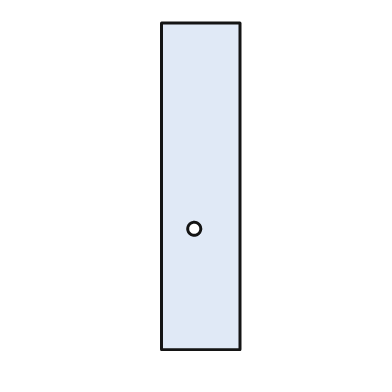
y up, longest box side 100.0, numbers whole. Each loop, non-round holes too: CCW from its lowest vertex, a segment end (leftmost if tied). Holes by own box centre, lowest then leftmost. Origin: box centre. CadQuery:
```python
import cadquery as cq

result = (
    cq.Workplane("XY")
    .moveTo(-12.0, -50.0)
    .lineTo(12.0, -50.0)
    .lineTo(12.0, 50.0)
    .lineTo(-12.0, 50.0)
    .close()
    .moveTo(-2.0, -13.0)
    .circle(2.0)
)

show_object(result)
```